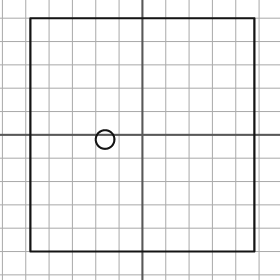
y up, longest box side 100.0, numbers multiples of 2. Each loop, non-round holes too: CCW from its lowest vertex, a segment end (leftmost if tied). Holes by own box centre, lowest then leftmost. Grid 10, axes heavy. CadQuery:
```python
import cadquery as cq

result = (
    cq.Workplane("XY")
    .moveTo(-48.0, -50.0)
    .lineTo(48.0, -50.0)
    .lineTo(48.0, 50.0)
    .lineTo(-48.0, 50.0)
    .close()
    .moveTo(-16.0, -2.0)
    .circle(4.0)
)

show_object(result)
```